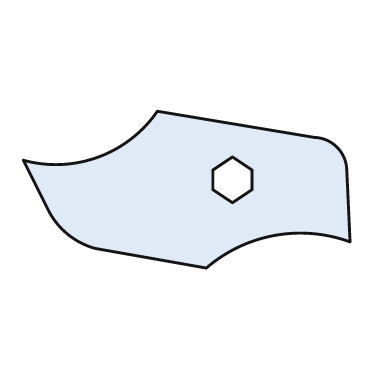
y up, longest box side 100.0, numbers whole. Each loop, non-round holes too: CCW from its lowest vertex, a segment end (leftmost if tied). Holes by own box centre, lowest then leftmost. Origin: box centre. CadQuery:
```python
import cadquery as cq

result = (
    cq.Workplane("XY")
    .moveTo(6.0, -24.0)
    .threePointArc((27.0, -14.0), (50.0, -16.0))
    .lineTo(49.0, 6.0)
    .threePointArc((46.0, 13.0), (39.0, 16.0))
    .lineTo(-9.0, 24.0)
    .threePointArc((-27.0, 10.0), (-50.0, 9.0))
    .lineTo(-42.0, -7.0)
    .threePointArc((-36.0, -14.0), (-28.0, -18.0))
    .close()
    .moveTo(14.0, -4.0)
    .lineTo(20.0, 0.0)
    .lineTo(20.0, 6.0)
    .lineTo(14.0, 10.0)
    .lineTo(8.0, 6.0)
    .lineTo(8.0, 0.0)
    .close()
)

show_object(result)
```